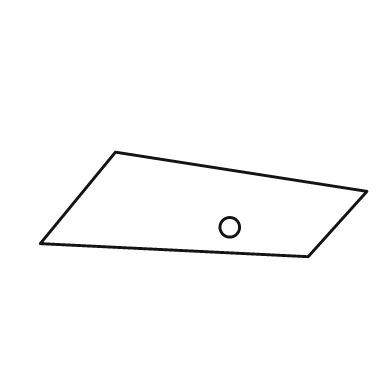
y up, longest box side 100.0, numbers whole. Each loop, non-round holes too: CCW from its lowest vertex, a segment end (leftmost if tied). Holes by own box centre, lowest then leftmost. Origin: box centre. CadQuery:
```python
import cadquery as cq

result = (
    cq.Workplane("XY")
    .moveTo(32.0, -16.0)
    .lineTo(50.0, 4.0)
    .lineTo(-27.0, 16.0)
    .lineTo(-50.0, -12.0)
    .close()
    .moveTo(8.0, -7.0)
    .circle(3.0)
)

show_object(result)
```